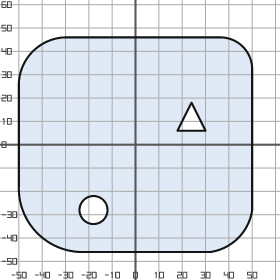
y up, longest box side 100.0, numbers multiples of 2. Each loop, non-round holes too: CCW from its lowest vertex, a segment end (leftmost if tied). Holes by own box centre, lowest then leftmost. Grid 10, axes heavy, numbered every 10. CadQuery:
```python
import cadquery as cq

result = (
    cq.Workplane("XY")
    .moveTo(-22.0, -46.0)
    .lineTo(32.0, -46.0)
    .threePointArc((44.0, -40.0), (50.0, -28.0))
    .lineTo(50.0, 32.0)
    .threePointArc((46.0, 42.0), (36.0, 46.0))
    .lineTo(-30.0, 46.0)
    .threePointArc((-44.0, 40.0), (-50.0, 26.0))
    .lineTo(-50.0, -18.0)
    .threePointArc((-42.0, -38.0), (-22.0, -46.0))
    .close()
    .moveTo(-18.0, -28.0)
    .circle(6.0)
    .moveTo(18.0, 6.0)
    .lineTo(30.0, 6.0)
    .lineTo(24.0, 18.0)
    .close()
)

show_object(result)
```